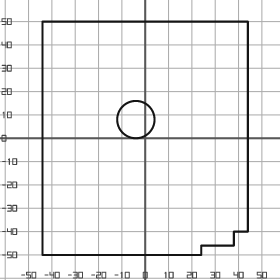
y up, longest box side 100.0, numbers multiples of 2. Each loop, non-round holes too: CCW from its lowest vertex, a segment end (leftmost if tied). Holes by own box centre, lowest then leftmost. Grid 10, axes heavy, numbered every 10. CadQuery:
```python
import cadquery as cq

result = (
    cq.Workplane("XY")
    .moveTo(-44.0, -50.0)
    .lineTo(24.0, -50.0)
    .lineTo(24.0, -46.0)
    .lineTo(38.0, -46.0)
    .lineTo(38.0, -40.0)
    .lineTo(44.0, -40.0)
    .lineTo(44.0, 50.0)
    .lineTo(-44.0, 50.0)
    .close()
    .moveTo(-4.0, 8.0)
    .circle(8.0)
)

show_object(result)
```